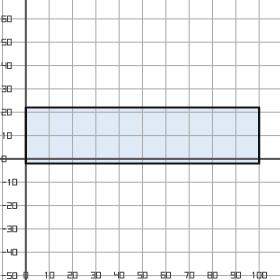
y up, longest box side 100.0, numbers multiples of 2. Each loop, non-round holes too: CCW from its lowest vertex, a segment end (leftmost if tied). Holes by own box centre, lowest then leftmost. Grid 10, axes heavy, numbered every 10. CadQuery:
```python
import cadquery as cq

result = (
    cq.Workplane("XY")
    .moveTo(0.0, -2.0)
    .lineTo(100.0, -2.0)
    .lineTo(100.0, 22.0)
    .lineTo(0.0, 22.0)
    .close()
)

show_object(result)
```